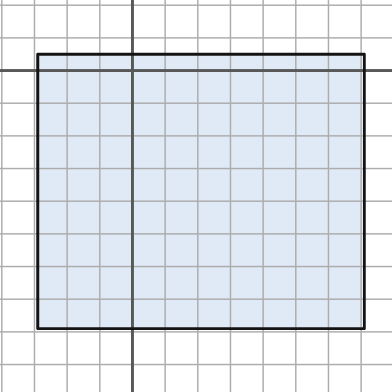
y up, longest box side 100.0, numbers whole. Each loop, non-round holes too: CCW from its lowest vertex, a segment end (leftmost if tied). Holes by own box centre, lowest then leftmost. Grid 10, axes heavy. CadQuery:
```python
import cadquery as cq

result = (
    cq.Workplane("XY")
    .moveTo(-29.0, -79.0)
    .lineTo(71.0, -79.0)
    .lineTo(71.0, 5.0)
    .lineTo(-29.0, 5.0)
    .close()
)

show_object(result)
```